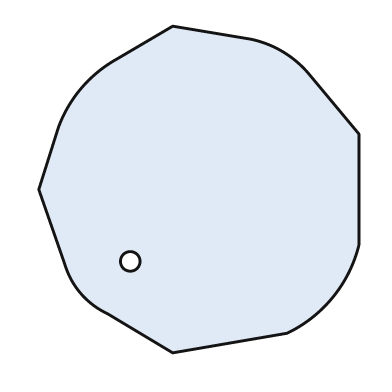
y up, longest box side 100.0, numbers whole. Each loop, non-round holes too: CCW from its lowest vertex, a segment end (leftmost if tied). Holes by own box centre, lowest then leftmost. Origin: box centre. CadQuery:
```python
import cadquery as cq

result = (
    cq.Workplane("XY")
    .moveTo(-8.0, -50.0)
    .lineTo(27.0, -44.0)
    .threePointArc((41.0, -33.0), (49.0, -17.0))
    .lineTo(49.0, 17.0)
    .lineTo(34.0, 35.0)
    .threePointArc((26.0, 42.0), (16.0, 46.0))
    .lineTo(-8.0, 50.0)
    .lineTo(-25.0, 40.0)
    .threePointArc((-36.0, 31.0), (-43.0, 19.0))
    .lineTo(-49.0, 0.0)
    .lineTo(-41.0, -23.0)
    .threePointArc((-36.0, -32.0), (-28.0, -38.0))
    .close()
    .moveTo(-21.0, -22.0)
    .circle(3.0)
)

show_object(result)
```